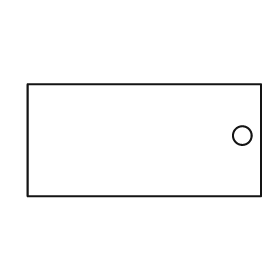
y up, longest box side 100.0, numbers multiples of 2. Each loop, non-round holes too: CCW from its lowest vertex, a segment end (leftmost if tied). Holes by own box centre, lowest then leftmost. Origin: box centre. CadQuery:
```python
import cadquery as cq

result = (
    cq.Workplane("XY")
    .moveTo(-50.0, -24.0)
    .lineTo(50.0, -24.0)
    .lineTo(50.0, 24.0)
    .lineTo(-50.0, 24.0)
    .close()
    .moveTo(42.0, 2.0)
    .circle(4.0)
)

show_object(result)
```